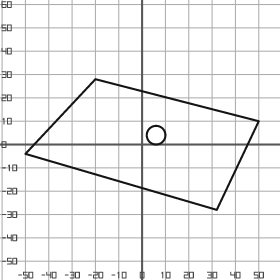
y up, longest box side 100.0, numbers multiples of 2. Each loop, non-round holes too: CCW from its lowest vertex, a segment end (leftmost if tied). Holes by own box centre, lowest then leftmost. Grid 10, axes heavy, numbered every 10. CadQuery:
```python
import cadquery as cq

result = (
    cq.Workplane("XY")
    .moveTo(32.0, -28.0)
    .lineTo(50.0, 10.0)
    .lineTo(-20.0, 28.0)
    .lineTo(-50.0, -4.0)
    .close()
    .moveTo(6.0, 4.0)
    .circle(4.0)
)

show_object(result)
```